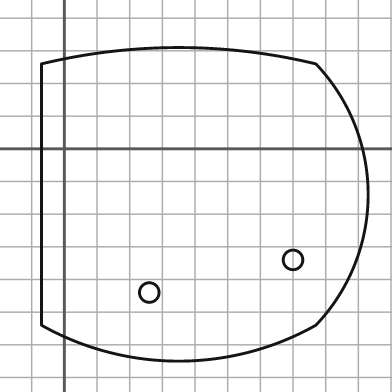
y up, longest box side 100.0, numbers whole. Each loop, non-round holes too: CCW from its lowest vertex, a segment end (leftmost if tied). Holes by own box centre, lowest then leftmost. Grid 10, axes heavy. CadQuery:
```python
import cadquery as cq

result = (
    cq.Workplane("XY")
    .moveTo(-7.0, -54.0)
    .threePointArc((35.0, -65.0), (77.0, -54.0))
    .threePointArc((93.0, -14.0), (77.0, 26.0))
    .threePointArc((35.0, 31.0), (-7.0, 26.0))
    .close()
    .moveTo(26.0, -44.0)
    .circle(3.0)
    .moveTo(70.0, -34.0)
    .circle(3.0)
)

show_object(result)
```